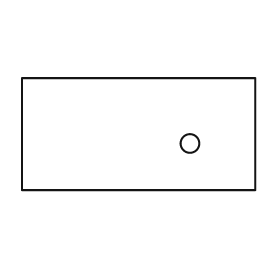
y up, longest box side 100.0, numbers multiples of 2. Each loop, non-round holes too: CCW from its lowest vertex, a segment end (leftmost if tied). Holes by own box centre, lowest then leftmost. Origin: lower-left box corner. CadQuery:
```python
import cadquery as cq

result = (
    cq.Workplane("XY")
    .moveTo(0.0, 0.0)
    .lineTo(100.0, 0.0)
    .lineTo(100.0, 48.0)
    .lineTo(0.0, 48.0)
    .close()
    .moveTo(72.0, 20.0)
    .circle(4.0)
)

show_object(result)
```